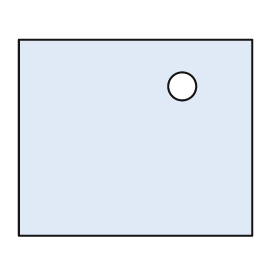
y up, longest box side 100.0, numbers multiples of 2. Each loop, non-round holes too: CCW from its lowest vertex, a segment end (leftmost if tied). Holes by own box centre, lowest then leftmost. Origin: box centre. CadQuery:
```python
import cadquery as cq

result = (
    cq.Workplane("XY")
    .moveTo(-50.0, -42.0)
    .lineTo(50.0, -42.0)
    .lineTo(50.0, 42.0)
    .lineTo(-50.0, 42.0)
    .close()
    .moveTo(20.0, 22.0)
    .circle(6.0)
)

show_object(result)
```